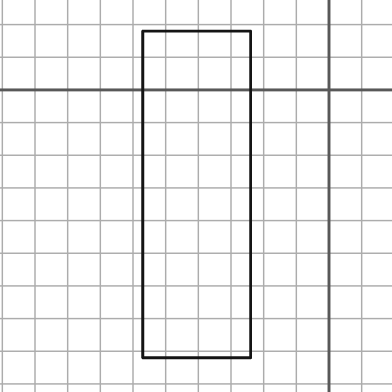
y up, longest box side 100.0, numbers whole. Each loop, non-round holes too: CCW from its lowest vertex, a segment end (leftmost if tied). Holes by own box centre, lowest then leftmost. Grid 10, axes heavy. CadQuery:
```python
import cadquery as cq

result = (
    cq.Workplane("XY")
    .moveTo(-57.0, -82.0)
    .lineTo(-24.0, -82.0)
    .lineTo(-24.0, 18.0)
    .lineTo(-57.0, 18.0)
    .close()
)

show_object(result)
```